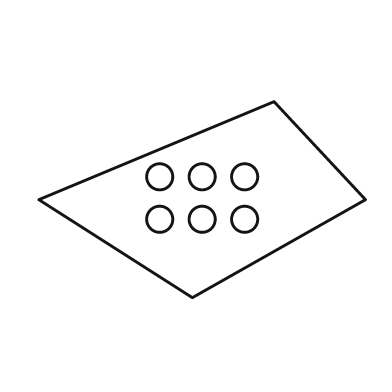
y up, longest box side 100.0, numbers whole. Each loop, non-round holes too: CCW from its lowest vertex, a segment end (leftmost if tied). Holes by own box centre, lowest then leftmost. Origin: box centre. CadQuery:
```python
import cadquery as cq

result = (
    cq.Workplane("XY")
    .moveTo(-3.0, -30.0)
    .lineTo(50.0, 0.0)
    .lineTo(22.0, 30.0)
    .lineTo(-50.0, 0.0)
    .close()
    .moveTo(-13.0, -6.0)
    .circle(4.0)
    .moveTo(0.0, -6.0)
    .circle(4.0)
    .moveTo(13.0, -6.0)
    .circle(4.0)
    .moveTo(-13.0, 7.0)
    .circle(4.0)
    .moveTo(0.0, 7.0)
    .circle(4.0)
    .moveTo(13.0, 7.0)
    .circle(4.0)
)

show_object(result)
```